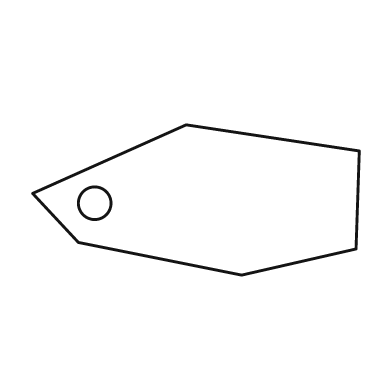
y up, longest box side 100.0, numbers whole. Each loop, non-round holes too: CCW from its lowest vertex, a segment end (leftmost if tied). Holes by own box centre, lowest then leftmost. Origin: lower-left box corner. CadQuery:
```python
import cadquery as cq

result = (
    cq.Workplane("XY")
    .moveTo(64.0, 0.0)
    .lineTo(99.0, 8.0)
    .lineTo(100.0, 38.0)
    .lineTo(47.0, 46.0)
    .lineTo(0.0, 25.0)
    .lineTo(14.0, 10.0)
    .close()
    .moveTo(19.0, 22.0)
    .circle(5.0)
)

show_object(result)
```